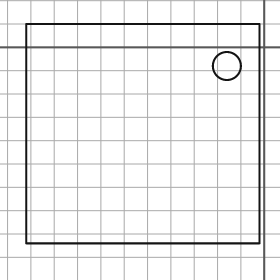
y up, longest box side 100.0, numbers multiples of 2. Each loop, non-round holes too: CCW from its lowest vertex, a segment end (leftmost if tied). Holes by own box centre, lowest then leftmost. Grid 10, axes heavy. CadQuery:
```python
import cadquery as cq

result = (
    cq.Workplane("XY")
    .moveTo(-102.0, -84.0)
    .lineTo(-2.0, -84.0)
    .lineTo(-2.0, 10.0)
    .lineTo(-102.0, 10.0)
    .close()
    .moveTo(-16.0, -8.0)
    .circle(6.0)
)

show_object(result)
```